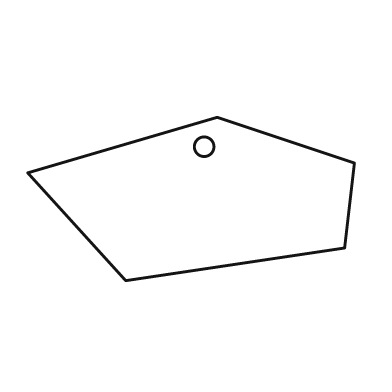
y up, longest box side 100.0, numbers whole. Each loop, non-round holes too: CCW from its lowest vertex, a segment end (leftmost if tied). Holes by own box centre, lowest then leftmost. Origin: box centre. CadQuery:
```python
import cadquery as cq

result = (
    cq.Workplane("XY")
    .moveTo(-20.0, -25.0)
    .lineTo(47.0, -15.0)
    .lineTo(50.0, 11.0)
    .lineTo(8.0, 25.0)
    .lineTo(-50.0, 8.0)
    .close()
    .moveTo(4.0, 16.0)
    .circle(3.0)
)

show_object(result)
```